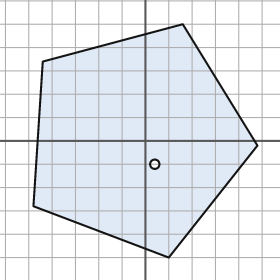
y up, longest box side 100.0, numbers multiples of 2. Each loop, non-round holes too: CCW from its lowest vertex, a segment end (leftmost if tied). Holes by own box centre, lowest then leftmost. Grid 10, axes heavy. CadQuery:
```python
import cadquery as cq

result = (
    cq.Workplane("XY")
    .moveTo(10.0, -50.0)
    .lineTo(48.0, -2.0)
    .lineTo(16.0, 50.0)
    .lineTo(-44.0, 34.0)
    .lineTo(-48.0, -28.0)
    .close()
    .moveTo(4.0, -10.0)
    .circle(2.0)
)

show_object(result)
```